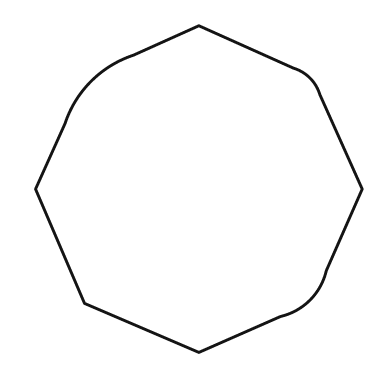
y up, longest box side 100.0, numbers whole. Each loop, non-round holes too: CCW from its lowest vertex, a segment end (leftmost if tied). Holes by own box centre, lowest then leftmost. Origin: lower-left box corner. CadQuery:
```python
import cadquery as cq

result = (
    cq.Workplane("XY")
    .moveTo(50.0, 0.0)
    .lineTo(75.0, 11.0)
    .threePointArc((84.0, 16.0), (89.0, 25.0))
    .lineTo(100.0, 50.0)
    .lineTo(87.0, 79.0)
    .threePointArc((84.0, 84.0), (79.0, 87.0))
    .lineTo(50.0, 100.0)
    .lineTo(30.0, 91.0)
    .threePointArc((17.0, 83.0), (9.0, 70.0))
    .lineTo(0.0, 50.0)
    .lineTo(15.0, 15.0)
    .close()
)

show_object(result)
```